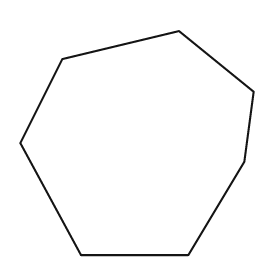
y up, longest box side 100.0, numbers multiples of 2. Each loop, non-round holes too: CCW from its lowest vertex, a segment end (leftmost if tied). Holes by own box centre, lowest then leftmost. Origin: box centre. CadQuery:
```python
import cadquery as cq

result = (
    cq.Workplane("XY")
    .moveTo(-24.0, -48.0)
    .lineTo(22.0, -48.0)
    .lineTo(46.0, -8.0)
    .lineTo(50.0, 22.0)
    .lineTo(18.0, 48.0)
    .lineTo(-32.0, 36.0)
    .lineTo(-50.0, 0.0)
    .close()
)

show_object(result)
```